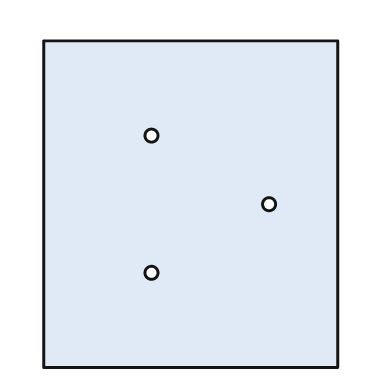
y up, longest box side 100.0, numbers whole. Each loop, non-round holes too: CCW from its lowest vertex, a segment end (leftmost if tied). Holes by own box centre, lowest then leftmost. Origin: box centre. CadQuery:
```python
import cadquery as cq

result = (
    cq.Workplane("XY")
    .moveTo(-45.0, -50.0)
    .lineTo(45.0, -50.0)
    .lineTo(45.0, 50.0)
    .lineTo(-45.0, 50.0)
    .close()
    .moveTo(-12.0, -21.0)
    .circle(2.0)
    .moveTo(24.0, 0.0)
    .circle(2.0)
    .moveTo(-12.0, 21.0)
    .circle(2.0)
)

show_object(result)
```